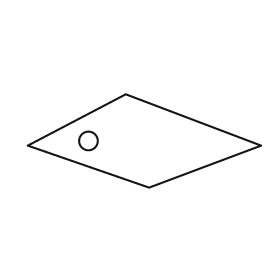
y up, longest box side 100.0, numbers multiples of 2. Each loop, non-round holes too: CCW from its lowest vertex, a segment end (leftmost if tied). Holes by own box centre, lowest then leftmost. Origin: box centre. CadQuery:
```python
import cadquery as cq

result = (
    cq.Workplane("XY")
    .moveTo(2.0, -20.0)
    .lineTo(50.0, -2.0)
    .lineTo(-8.0, 20.0)
    .lineTo(-50.0, -2.0)
    .close()
    .moveTo(-24.0, 0.0)
    .circle(4.0)
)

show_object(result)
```